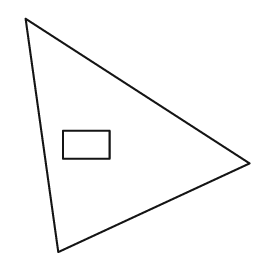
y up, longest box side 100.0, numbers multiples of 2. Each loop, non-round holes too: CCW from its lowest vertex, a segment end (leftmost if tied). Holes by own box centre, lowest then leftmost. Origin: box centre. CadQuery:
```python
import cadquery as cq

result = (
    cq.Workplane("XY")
    .moveTo(-34.0, -50.0)
    .lineTo(48.0, -12.0)
    .lineTo(-48.0, 50.0)
    .close()
    .moveTo(-32.0, -10.0)
    .lineTo(-12.0, -10.0)
    .lineTo(-12.0, 2.0)
    .lineTo(-32.0, 2.0)
    .close()
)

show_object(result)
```